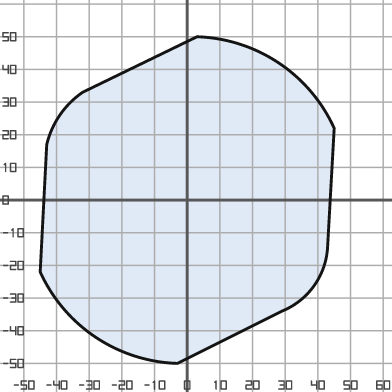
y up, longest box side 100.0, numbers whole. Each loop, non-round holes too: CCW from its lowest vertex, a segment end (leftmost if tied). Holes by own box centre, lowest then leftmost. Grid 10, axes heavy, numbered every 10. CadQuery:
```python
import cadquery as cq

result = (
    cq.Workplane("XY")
    .moveTo(-3.0, -50.0)
    .lineTo(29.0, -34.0)
    .threePointArc((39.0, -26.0), (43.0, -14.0))
    .lineTo(45.0, 22.0)
    .threePointArc((28.0, 42.0), (3.0, 50.0))
    .lineTo(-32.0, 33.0)
    .threePointArc((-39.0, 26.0), (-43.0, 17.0))
    .lineTo(-45.0, -22.0)
    .threePointArc((-28.0, -42.0), (-3.0, -50.0))
    .close()
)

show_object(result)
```